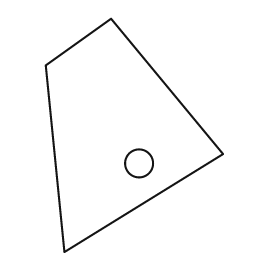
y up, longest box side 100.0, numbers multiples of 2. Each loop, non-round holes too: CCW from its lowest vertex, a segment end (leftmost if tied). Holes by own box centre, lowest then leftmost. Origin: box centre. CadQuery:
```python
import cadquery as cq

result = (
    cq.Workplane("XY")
    .moveTo(-30.0, -50.0)
    .lineTo(38.0, -8.0)
    .lineTo(-10.0, 50.0)
    .lineTo(-38.0, 30.0)
    .close()
    .moveTo(2.0, -12.0)
    .circle(6.0)
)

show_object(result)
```